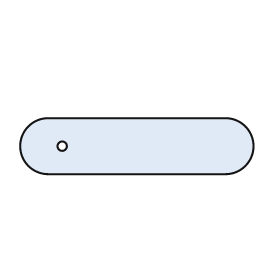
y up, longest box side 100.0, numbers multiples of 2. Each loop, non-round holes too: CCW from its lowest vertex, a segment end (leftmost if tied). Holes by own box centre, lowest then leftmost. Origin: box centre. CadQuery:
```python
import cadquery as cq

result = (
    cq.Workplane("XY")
    .moveTo(-38.0, -12.0)
    .lineTo(38.0, -12.0)
    .threePointArc((50.0, 0.0), (38.0, 12.0))
    .lineTo(-38.0, 12.0)
    .threePointArc((-50.0, 0.0), (-38.0, -12.0))
    .close()
    .moveTo(-32.0, 0.0)
    .circle(2.0)
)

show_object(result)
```